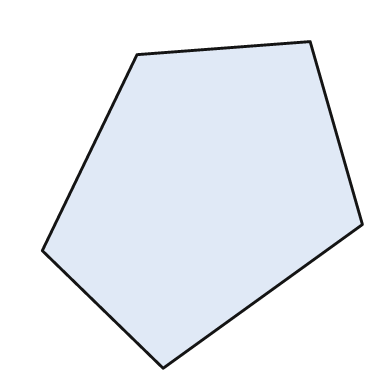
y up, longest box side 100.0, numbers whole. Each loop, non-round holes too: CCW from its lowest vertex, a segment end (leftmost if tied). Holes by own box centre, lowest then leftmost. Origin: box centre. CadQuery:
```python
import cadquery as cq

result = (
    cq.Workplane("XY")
    .moveTo(-12.0, -50.0)
    .lineTo(49.0, -6.0)
    .lineTo(33.0, 50.0)
    .lineTo(-20.0, 46.0)
    .lineTo(-49.0, -14.0)
    .close()
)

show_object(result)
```